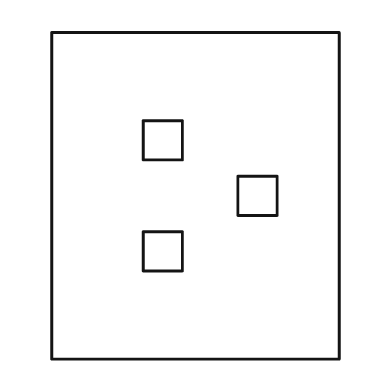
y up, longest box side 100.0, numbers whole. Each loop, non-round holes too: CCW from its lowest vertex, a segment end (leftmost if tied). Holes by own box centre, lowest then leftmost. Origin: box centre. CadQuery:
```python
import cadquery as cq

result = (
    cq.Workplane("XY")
    .moveTo(-44.0, -50.0)
    .lineTo(44.0, -50.0)
    .lineTo(44.0, 50.0)
    .lineTo(-44.0, 50.0)
    .close()
    .moveTo(-16.0, -23.0)
    .lineTo(-4.0, -23.0)
    .lineTo(-4.0, -11.0)
    .lineTo(-16.0, -11.0)
    .close()
    .moveTo(13.0, -6.0)
    .lineTo(25.0, -6.0)
    .lineTo(25.0, 6.0)
    .lineTo(13.0, 6.0)
    .close()
    .moveTo(-16.0, 11.0)
    .lineTo(-4.0, 11.0)
    .lineTo(-4.0, 23.0)
    .lineTo(-16.0, 23.0)
    .close()
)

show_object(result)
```